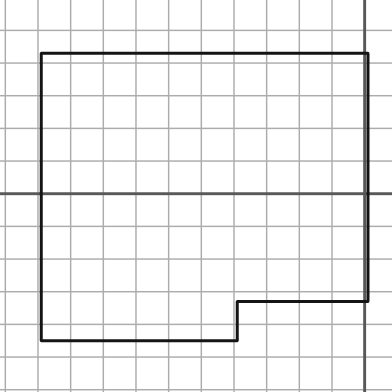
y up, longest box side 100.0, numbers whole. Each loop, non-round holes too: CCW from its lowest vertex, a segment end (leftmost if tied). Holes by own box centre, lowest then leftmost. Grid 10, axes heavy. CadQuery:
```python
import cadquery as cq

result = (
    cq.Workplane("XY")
    .moveTo(-99.0, -45.0)
    .lineTo(-39.0, -45.0)
    .lineTo(-39.0, -33.0)
    .lineTo(1.0, -33.0)
    .lineTo(1.0, 43.0)
    .lineTo(-99.0, 43.0)
    .close()
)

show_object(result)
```